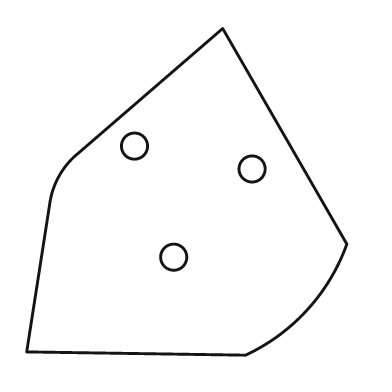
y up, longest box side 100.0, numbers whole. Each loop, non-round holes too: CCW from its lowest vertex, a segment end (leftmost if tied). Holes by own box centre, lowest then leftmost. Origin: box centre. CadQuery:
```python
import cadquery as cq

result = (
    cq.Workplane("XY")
    .moveTo(18.0, -50.0)
    .threePointArc((37.0, -36.0), (49.0, -16.0))
    .lineTo(11.0, 50.0)
    .lineTo(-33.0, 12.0)
    .threePointArc((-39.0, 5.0), (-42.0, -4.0))
    .lineTo(-49.0, -49.0)
    .close()
    .moveTo(-4.0, -20.0)
    .circle(4.0)
    .moveTo(20.0, 7.0)
    .circle(4.0)
    .moveTo(-16.0, 14.0)
    .circle(4.0)
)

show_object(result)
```